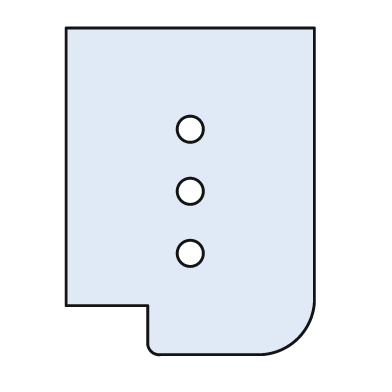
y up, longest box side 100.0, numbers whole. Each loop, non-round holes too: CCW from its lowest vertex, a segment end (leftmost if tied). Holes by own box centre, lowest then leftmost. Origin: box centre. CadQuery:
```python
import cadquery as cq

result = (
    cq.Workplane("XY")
    .moveTo(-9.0, -50.0)
    .lineTo(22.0, -50.0)
    .threePointArc((33.0, -45.0), (38.0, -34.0))
    .lineTo(38.0, 50.0)
    .lineTo(-38.0, 50.0)
    .lineTo(-38.0, -35.0)
    .lineTo(-13.0, -35.0)
    .lineTo(-13.0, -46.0)
    .threePointArc((-12.0, -49.0), (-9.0, -50.0))
    .close()
    .moveTo(0.0, -19.0)
    .circle(4.0)
    .moveTo(0.0, 0.0)
    .circle(4.0)
    .moveTo(0.0, 19.0)
    .circle(4.0)
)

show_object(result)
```